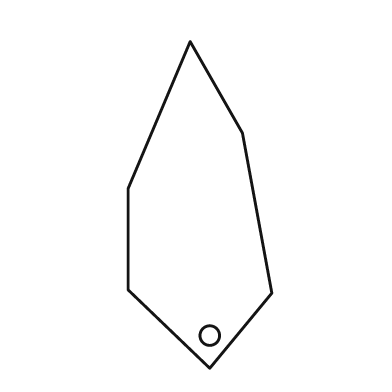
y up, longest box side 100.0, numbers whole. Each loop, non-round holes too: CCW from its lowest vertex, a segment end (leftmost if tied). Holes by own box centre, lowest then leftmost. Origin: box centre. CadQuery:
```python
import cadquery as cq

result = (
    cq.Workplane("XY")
    .moveTo(3.0, -50.0)
    .lineTo(22.0, -27.0)
    .lineTo(13.0, 22.0)
    .lineTo(-3.0, 50.0)
    .lineTo(-22.0, 5.0)
    .lineTo(-22.0, -26.0)
    .close()
    .moveTo(3.0, -40.0)
    .circle(3.0)
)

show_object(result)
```